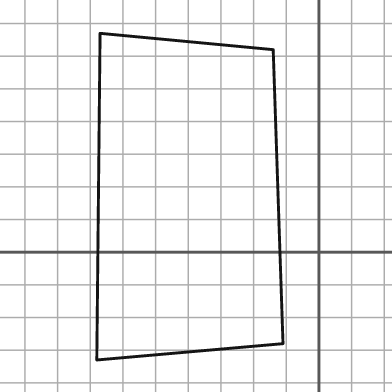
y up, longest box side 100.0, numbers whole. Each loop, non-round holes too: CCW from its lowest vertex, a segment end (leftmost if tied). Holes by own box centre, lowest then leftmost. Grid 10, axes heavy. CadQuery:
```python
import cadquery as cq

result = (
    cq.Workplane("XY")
    .moveTo(-68.0, -33.0)
    .lineTo(-11.0, -28.0)
    .lineTo(-14.0, 62.0)
    .lineTo(-67.0, 67.0)
    .close()
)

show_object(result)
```